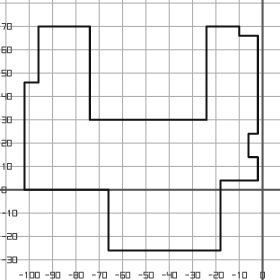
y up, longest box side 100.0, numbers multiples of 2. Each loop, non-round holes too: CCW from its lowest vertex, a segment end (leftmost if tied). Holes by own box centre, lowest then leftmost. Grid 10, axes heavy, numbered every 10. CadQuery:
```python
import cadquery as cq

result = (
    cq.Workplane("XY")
    .moveTo(-66.0, -26.0)
    .lineTo(-18.0, -26.0)
    .lineTo(-18.0, 4.0)
    .lineTo(-2.0, 4.0)
    .lineTo(-2.0, 14.0)
    .lineTo(-6.0, 14.0)
    .lineTo(-6.0, 24.0)
    .lineTo(-2.0, 24.0)
    .lineTo(-2.0, 66.0)
    .lineTo(-10.0, 66.0)
    .lineTo(-10.0, 70.0)
    .lineTo(-24.0, 70.0)
    .lineTo(-24.0, 30.0)
    .lineTo(-74.0, 30.0)
    .lineTo(-74.0, 70.0)
    .lineTo(-96.0, 70.0)
    .lineTo(-96.0, 46.0)
    .lineTo(-102.0, 46.0)
    .lineTo(-102.0, 0.0)
    .lineTo(-66.0, 0.0)
    .close()
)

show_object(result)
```